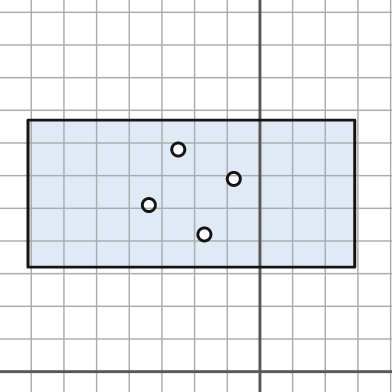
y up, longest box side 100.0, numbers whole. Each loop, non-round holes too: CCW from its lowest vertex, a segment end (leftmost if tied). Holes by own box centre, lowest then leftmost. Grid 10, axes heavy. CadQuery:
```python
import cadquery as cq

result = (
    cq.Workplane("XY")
    .moveTo(-71.0, 32.0)
    .lineTo(29.0, 32.0)
    .lineTo(29.0, 77.0)
    .lineTo(-71.0, 77.0)
    .close()
    .moveTo(-17.0, 42.0)
    .circle(2.0)
    .moveTo(-34.0, 51.0)
    .circle(2.0)
    .moveTo(-8.0, 59.0)
    .circle(2.0)
    .moveTo(-25.0, 68.0)
    .circle(2.0)
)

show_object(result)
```